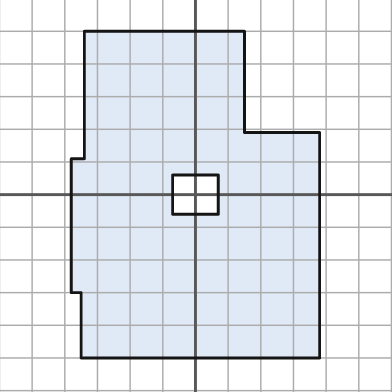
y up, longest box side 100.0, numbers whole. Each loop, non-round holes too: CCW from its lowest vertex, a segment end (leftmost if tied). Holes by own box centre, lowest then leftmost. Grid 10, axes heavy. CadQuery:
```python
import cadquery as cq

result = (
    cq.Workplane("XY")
    .moveTo(-35.0, -50.0)
    .lineTo(38.0, -50.0)
    .lineTo(38.0, 19.0)
    .lineTo(15.0, 19.0)
    .lineTo(15.0, 50.0)
    .lineTo(-34.0, 50.0)
    .lineTo(-34.0, 11.0)
    .lineTo(-38.0, 11.0)
    .lineTo(-38.0, -30.0)
    .lineTo(-35.0, -30.0)
    .close()
    .moveTo(-7.0, -6.0)
    .lineTo(7.0, -6.0)
    .lineTo(7.0, 6.0)
    .lineTo(-7.0, 6.0)
    .close()
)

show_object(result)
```